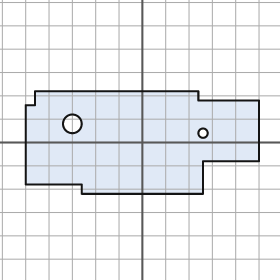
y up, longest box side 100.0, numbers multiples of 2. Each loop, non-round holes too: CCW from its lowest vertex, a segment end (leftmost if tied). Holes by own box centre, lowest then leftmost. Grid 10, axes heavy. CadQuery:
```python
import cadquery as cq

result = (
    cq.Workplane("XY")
    .moveTo(-26.0, -22.0)
    .lineTo(26.0, -22.0)
    .lineTo(26.0, -8.0)
    .lineTo(50.0, -8.0)
    .lineTo(50.0, 18.0)
    .lineTo(24.0, 18.0)
    .lineTo(24.0, 22.0)
    .lineTo(-46.0, 22.0)
    .lineTo(-46.0, 16.0)
    .lineTo(-50.0, 16.0)
    .lineTo(-50.0, -18.0)
    .lineTo(-26.0, -18.0)
    .close()
    .moveTo(26.0, 4.0)
    .circle(2.0)
    .moveTo(-30.0, 8.0)
    .circle(4.0)
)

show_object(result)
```